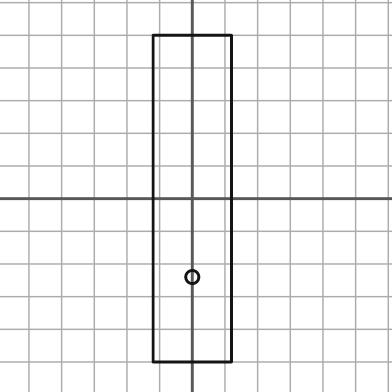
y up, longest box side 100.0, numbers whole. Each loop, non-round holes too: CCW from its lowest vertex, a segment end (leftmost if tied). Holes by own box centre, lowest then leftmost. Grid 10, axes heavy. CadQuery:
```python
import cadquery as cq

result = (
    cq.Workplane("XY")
    .moveTo(-12.0, -50.0)
    .lineTo(12.0, -50.0)
    .lineTo(12.0, 50.0)
    .lineTo(-12.0, 50.0)
    .close()
    .moveTo(0.0, -24.0)
    .circle(2.0)
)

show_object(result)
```